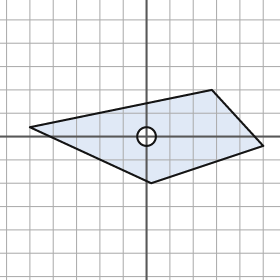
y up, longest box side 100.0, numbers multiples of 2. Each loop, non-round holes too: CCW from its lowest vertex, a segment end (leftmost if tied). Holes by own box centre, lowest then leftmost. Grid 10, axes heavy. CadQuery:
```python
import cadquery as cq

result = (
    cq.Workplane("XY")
    .moveTo(2.0, -20.0)
    .lineTo(50.0, -4.0)
    .lineTo(28.0, 20.0)
    .lineTo(-50.0, 4.0)
    .close()
    .moveTo(0.0, 0.0)
    .circle(4.0)
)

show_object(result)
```